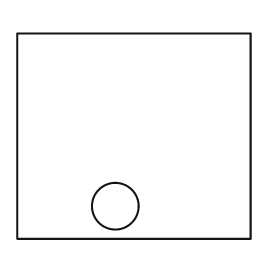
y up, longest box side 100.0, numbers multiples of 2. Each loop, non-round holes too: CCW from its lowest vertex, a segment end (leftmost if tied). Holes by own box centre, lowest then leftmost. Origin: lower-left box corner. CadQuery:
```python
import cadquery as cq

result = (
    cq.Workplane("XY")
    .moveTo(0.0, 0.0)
    .lineTo(100.0, 0.0)
    .lineTo(100.0, 88.0)
    .lineTo(0.0, 88.0)
    .close()
    .moveTo(42.0, 14.0)
    .circle(10.0)
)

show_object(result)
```